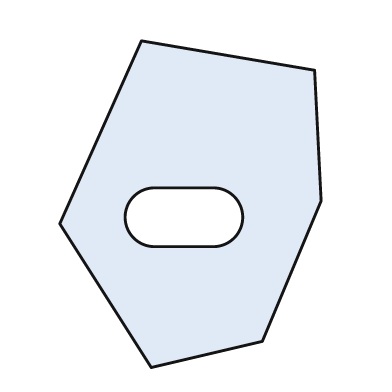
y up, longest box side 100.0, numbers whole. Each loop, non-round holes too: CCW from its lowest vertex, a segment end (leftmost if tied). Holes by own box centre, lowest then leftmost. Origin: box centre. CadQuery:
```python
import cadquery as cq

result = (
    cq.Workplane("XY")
    .moveTo(-12.0, -50.0)
    .lineTo(22.0, -42.0)
    .lineTo(40.0, 1.0)
    .lineTo(38.0, 41.0)
    .lineTo(-15.0, 50.0)
    .lineTo(-40.0, -6.0)
    .close()
    .moveTo(-11.0, -13.0)
    .lineTo(7.0, -13.0)
    .threePointArc((16.0, -4.0), (7.0, 5.0))
    .lineTo(-11.0, 5.0)
    .threePointArc((-20.0, -4.0), (-11.0, -13.0))
    .close()
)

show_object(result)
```